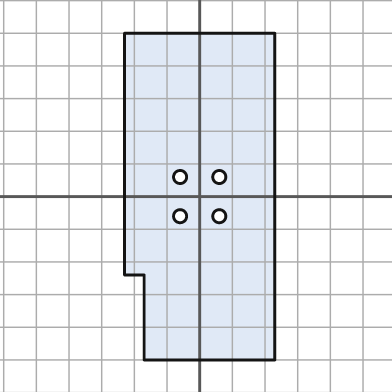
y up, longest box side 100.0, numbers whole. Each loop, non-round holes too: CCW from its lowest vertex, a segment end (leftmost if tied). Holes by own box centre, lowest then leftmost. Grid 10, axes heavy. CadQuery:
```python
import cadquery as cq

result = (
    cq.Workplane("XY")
    .moveTo(-17.0, -50.0)
    .lineTo(23.0, -50.0)
    .lineTo(23.0, 50.0)
    .lineTo(-23.0, 50.0)
    .lineTo(-23.0, -24.0)
    .lineTo(-17.0, -24.0)
    .close()
    .moveTo(-6.0, -6.0)
    .circle(2.0)
    .moveTo(6.0, -6.0)
    .circle(2.0)
    .moveTo(-6.0, 6.0)
    .circle(2.0)
    .moveTo(6.0, 6.0)
    .circle(2.0)
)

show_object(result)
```